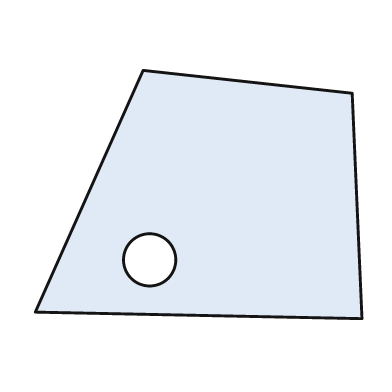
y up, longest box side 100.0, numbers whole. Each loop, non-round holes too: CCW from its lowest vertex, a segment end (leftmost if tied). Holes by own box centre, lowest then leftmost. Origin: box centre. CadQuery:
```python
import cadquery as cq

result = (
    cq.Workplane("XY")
    .moveTo(50.0, -38.0)
    .lineTo(47.0, 31.0)
    .lineTo(-17.0, 38.0)
    .lineTo(-50.0, -36.0)
    .close()
    .moveTo(-15.0, -20.0)
    .circle(8.0)
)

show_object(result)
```